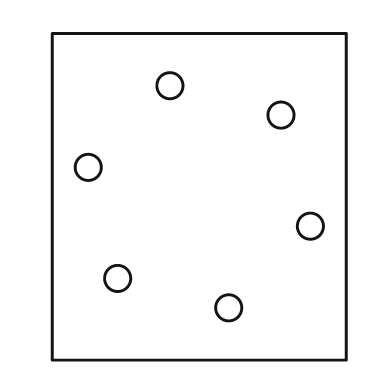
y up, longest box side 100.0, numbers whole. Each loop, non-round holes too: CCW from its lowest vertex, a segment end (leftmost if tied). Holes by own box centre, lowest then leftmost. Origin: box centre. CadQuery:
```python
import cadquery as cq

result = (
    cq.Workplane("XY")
    .moveTo(-45.0, -50.0)
    .lineTo(45.0, -50.0)
    .lineTo(45.0, 50.0)
    .lineTo(-45.0, 50.0)
    .close()
    .moveTo(9.0, -34.0)
    .circle(4.0)
    .moveTo(-25.0, -25.0)
    .circle(4.0)
    .moveTo(34.0, -9.0)
    .circle(4.0)
    .moveTo(-34.0, 9.0)
    .circle(4.0)
    .moveTo(25.0, 25.0)
    .circle(4.0)
    .moveTo(-9.0, 34.0)
    .circle(4.0)
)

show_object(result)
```